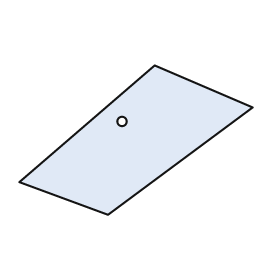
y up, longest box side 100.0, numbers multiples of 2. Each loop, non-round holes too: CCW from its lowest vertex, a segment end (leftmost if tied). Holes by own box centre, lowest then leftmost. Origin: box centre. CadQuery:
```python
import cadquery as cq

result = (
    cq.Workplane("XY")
    .moveTo(-12.0, -32.0)
    .lineTo(50.0, 14.0)
    .lineTo(8.0, 32.0)
    .lineTo(-50.0, -18.0)
    .close()
    .moveTo(-6.0, 8.0)
    .circle(2.0)
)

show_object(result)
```